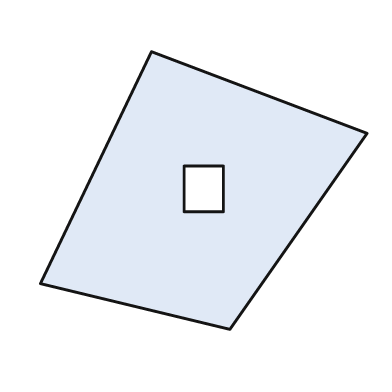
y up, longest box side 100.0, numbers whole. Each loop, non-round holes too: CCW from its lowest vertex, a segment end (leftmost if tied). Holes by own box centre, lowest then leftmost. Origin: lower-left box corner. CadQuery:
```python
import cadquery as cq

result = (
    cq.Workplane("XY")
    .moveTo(58.0, 0.0)
    .lineTo(100.0, 60.0)
    .lineTo(34.0, 85.0)
    .lineTo(0.0, 14.0)
    .close()
    .moveTo(44.0, 36.0)
    .lineTo(56.0, 36.0)
    .lineTo(56.0, 50.0)
    .lineTo(44.0, 50.0)
    .close()
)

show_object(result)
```